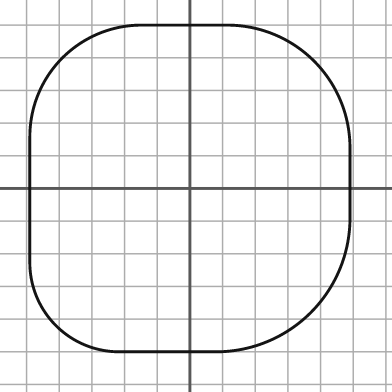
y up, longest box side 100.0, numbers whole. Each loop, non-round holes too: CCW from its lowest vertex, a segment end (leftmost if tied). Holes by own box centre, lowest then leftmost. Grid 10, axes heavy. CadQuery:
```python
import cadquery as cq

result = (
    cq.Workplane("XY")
    .moveTo(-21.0, -50.0)
    .lineTo(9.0, -50.0)
    .threePointArc((37.0, -38.0), (49.0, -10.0))
    .lineTo(49.0, 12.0)
    .threePointArc((38.0, 39.0), (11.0, 50.0))
    .lineTo(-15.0, 50.0)
    .threePointArc((-39.0, 40.0), (-49.0, 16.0))
    .lineTo(-49.0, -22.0)
    .threePointArc((-41.0, -42.0), (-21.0, -50.0))
    .close()
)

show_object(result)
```